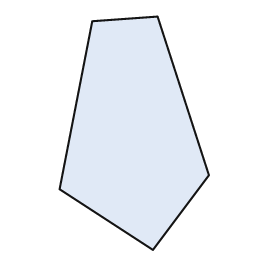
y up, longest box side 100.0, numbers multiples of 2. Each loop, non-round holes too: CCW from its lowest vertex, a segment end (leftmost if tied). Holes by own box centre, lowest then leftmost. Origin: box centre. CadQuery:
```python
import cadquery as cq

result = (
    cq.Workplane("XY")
    .moveTo(8.0, -50.0)
    .lineTo(32.0, -18.0)
    .lineTo(10.0, 50.0)
    .lineTo(-18.0, 48.0)
    .lineTo(-32.0, -24.0)
    .close()
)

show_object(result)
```